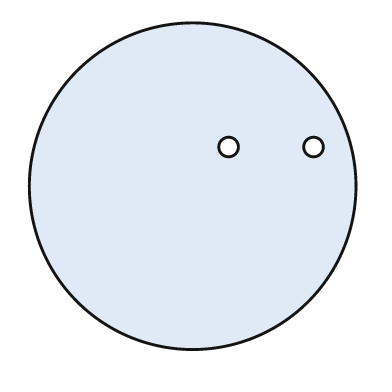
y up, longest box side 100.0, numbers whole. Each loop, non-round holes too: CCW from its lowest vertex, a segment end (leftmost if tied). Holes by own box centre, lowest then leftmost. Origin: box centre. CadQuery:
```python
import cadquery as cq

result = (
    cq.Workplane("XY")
    .moveTo(0.0, 0.0)
    .circle(50.0)
    .moveTo(11.0, 12.0)
    .circle(3.0)
    .moveTo(37.0, 12.0)
    .circle(3.0)
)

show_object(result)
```